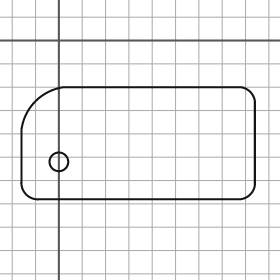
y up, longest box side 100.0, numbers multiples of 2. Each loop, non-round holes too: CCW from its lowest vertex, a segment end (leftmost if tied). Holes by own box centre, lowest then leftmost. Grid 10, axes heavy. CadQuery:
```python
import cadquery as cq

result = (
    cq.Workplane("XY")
    .moveTo(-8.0, -68.0)
    .lineTo(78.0, -68.0)
    .threePointArc((82.0, -66.0), (84.0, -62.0))
    .lineTo(84.0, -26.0)
    .threePointArc((82.0, -22.0), (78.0, -20.0))
    .lineTo(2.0, -20.0)
    .threePointArc((-10.0, -26.0), (-16.0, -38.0))
    .lineTo(-16.0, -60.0)
    .threePointArc((-14.0, -66.0), (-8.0, -68.0))
    .close()
    .moveTo(0.0, -52.0)
    .circle(4.0)
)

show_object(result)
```